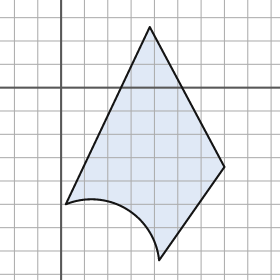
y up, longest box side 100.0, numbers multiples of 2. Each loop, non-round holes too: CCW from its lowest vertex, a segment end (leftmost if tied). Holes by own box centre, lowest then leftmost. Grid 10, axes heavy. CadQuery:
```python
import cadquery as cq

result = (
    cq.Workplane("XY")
    .moveTo(42.0, -74.0)
    .lineTo(70.0, -34.0)
    .lineTo(38.0, 26.0)
    .lineTo(2.0, -50.0)
    .threePointArc((28.0, -52.0), (42.0, -74.0))
    .close()
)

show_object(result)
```